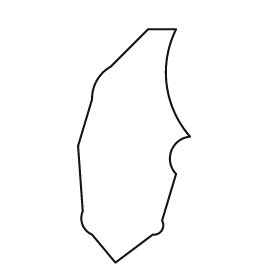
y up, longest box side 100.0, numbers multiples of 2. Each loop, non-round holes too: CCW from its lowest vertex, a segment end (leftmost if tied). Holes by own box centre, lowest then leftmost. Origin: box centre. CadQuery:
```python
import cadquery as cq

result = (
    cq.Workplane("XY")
    .moveTo(-8.0, -50.0)
    .lineTo(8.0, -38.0)
    .threePointArc((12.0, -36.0), (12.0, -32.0))
    .lineTo(18.0, -12.0)
    .threePointArc((16.0, -2.0), (24.0, 4.0))
    .threePointArc((14.0, 26.0), (18.0, 50.0))
    .lineTo(6.0, 50.0)
    .lineTo(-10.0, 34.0)
    .threePointArc((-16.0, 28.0), (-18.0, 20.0))
    .lineTo(-24.0, 0.0)
    .lineTo(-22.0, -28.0)
    .threePointArc((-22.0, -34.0), (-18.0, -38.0))
    .close()
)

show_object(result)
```